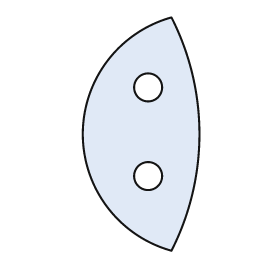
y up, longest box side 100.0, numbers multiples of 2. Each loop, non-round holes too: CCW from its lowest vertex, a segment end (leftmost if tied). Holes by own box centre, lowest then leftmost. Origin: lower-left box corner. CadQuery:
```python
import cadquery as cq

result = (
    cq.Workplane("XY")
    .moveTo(38.0, 0.0)
    .threePointArc((50.0, 50.0), (38.0, 100.0))
    .threePointArc((0.0, 50.0), (38.0, 0.0))
    .close()
    .moveTo(28.0, 32.0)
    .circle(6.0)
    .moveTo(28.0, 70.0)
    .circle(6.0)
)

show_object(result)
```